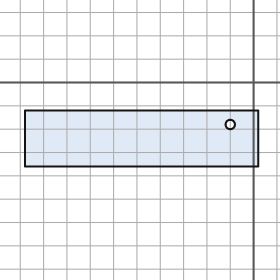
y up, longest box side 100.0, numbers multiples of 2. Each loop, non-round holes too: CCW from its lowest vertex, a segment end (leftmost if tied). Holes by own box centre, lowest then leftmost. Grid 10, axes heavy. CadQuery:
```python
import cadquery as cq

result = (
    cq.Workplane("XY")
    .moveTo(-98.0, -36.0)
    .lineTo(2.0, -36.0)
    .lineTo(2.0, -12.0)
    .lineTo(-98.0, -12.0)
    .close()
    .moveTo(-10.0, -18.0)
    .circle(2.0)
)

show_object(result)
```